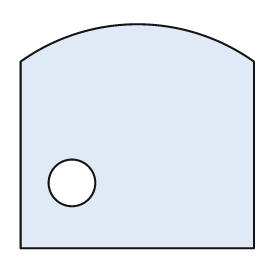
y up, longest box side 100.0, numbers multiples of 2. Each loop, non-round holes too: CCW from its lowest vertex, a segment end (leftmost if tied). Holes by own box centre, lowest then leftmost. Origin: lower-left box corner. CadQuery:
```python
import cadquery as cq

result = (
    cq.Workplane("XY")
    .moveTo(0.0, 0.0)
    .lineTo(100.0, 0.0)
    .lineTo(100.0, 80.0)
    .threePointArc((50.0, 96.0), (0.0, 80.0))
    .close()
    .moveTo(22.0, 28.0)
    .circle(10.0)
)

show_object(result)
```